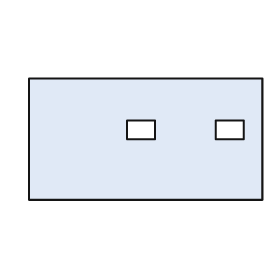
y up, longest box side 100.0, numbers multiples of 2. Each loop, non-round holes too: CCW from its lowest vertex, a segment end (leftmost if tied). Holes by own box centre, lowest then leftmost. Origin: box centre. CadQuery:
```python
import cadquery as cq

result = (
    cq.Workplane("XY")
    .moveTo(-50.0, -26.0)
    .lineTo(50.0, -26.0)
    .lineTo(50.0, 26.0)
    .lineTo(-50.0, 26.0)
    .close()
    .moveTo(-8.0, 0.0)
    .lineTo(4.0, 0.0)
    .lineTo(4.0, 8.0)
    .lineTo(-8.0, 8.0)
    .close()
    .moveTo(30.0, 0.0)
    .lineTo(42.0, 0.0)
    .lineTo(42.0, 8.0)
    .lineTo(30.0, 8.0)
    .close()
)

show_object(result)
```